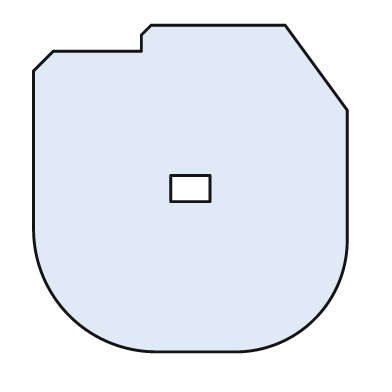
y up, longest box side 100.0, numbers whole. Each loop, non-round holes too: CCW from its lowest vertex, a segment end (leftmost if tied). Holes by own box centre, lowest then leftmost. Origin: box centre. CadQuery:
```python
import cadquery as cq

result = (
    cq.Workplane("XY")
    .moveTo(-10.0, -50.0)
    .lineTo(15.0, -50.0)
    .threePointArc((38.0, -40.0), (48.0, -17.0))
    .lineTo(48.0, 24.0)
    .lineTo(29.0, 50.0)
    .lineTo(-12.0, 50.0)
    .lineTo(-15.0, 47.0)
    .lineTo(-15.0, 42.0)
    .lineTo(-42.0, 42.0)
    .lineTo(-48.0, 36.0)
    .lineTo(-48.0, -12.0)
    .threePointArc((-37.0, -39.0), (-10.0, -50.0))
    .close()
    .moveTo(-6.0, -4.0)
    .lineTo(6.0, -4.0)
    .lineTo(6.0, 4.0)
    .lineTo(-6.0, 4.0)
    .close()
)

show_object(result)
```